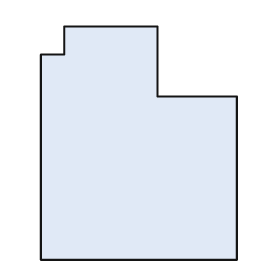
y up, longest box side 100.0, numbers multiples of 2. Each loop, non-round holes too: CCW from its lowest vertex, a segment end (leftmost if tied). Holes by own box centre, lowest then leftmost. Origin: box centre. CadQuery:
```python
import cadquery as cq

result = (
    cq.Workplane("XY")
    .moveTo(-42.0, -50.0)
    .lineTo(42.0, -50.0)
    .lineTo(42.0, 20.0)
    .lineTo(8.0, 20.0)
    .lineTo(8.0, 50.0)
    .lineTo(-32.0, 50.0)
    .lineTo(-32.0, 38.0)
    .lineTo(-42.0, 38.0)
    .close()
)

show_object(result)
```